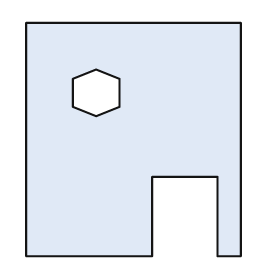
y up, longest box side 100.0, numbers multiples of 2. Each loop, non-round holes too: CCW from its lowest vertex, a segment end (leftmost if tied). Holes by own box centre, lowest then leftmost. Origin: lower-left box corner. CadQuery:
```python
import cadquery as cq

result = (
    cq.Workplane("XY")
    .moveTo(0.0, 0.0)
    .lineTo(54.0, 0.0)
    .lineTo(54.0, 34.0)
    .lineTo(82.0, 34.0)
    .lineTo(82.0, 0.0)
    .lineTo(92.0, 0.0)
    .lineTo(92.0, 100.0)
    .lineTo(0.0, 100.0)
    .close()
    .moveTo(30.0, 60.0)
    .lineTo(40.0, 64.0)
    .lineTo(40.0, 76.0)
    .lineTo(30.0, 80.0)
    .lineTo(20.0, 76.0)
    .lineTo(20.0, 64.0)
    .close()
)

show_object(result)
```